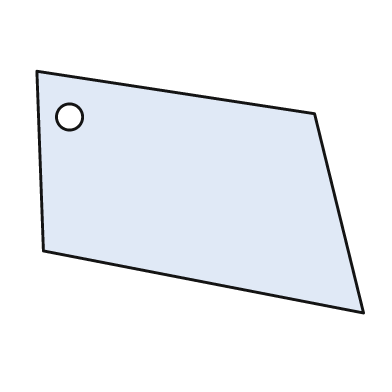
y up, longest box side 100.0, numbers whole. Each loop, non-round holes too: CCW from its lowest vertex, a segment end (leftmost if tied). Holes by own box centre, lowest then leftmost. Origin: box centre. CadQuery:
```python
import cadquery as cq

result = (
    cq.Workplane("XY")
    .moveTo(50.0, -37.0)
    .lineTo(35.0, 24.0)
    .lineTo(-50.0, 37.0)
    .lineTo(-48.0, -18.0)
    .close()
    .moveTo(-40.0, 23.0)
    .circle(4.0)
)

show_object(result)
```